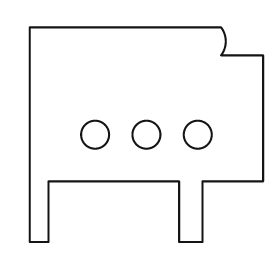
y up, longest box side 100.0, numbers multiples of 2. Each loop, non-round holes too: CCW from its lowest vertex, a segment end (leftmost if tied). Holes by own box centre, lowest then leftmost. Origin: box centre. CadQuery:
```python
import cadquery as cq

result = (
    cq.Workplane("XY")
    .moveTo(-50.0, -46.0)
    .lineTo(-42.0, -46.0)
    .lineTo(-42.0, -20.0)
    .lineTo(14.0, -20.0)
    .lineTo(14.0, -46.0)
    .lineTo(24.0, -46.0)
    .lineTo(24.0, -20.0)
    .lineTo(50.0, -20.0)
    .lineTo(50.0, 34.0)
    .lineTo(32.0, 34.0)
    .threePointArc((34.0, 40.0), (32.0, 46.0))
    .lineTo(-50.0, 46.0)
    .close()
    .moveTo(-22.0, 0.0)
    .circle(6.0)
    .moveTo(0.0, 0.0)
    .circle(6.0)
    .moveTo(22.0, 0.0)
    .circle(6.0)
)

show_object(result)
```